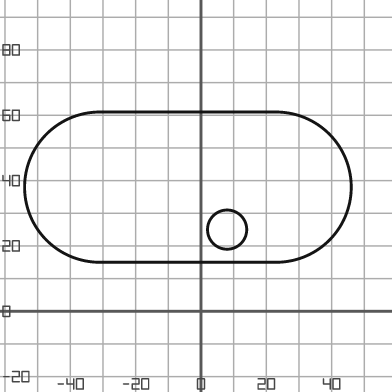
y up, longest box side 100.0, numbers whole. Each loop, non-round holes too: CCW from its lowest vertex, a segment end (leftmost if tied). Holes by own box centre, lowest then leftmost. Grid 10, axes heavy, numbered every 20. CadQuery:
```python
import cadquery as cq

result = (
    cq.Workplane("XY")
    .moveTo(-31.0, 15.0)
    .lineTo(23.0, 15.0)
    .threePointArc((46.0, 38.0), (23.0, 61.0))
    .lineTo(-31.0, 61.0)
    .threePointArc((-54.0, 38.0), (-31.0, 15.0))
    .close()
    .moveTo(8.0, 25.0)
    .circle(6.0)
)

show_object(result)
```